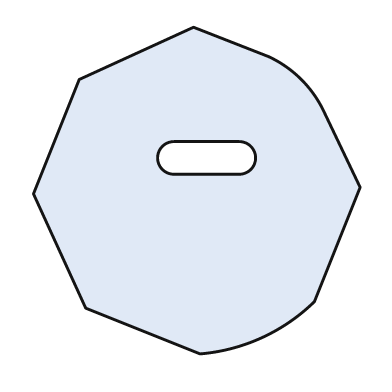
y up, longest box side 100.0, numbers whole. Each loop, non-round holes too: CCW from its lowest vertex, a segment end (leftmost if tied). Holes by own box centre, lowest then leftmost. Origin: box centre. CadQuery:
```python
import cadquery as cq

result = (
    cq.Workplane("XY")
    .moveTo(1.0, -50.0)
    .threePointArc((20.0, -45.0), (36.0, -34.0))
    .lineTo(50.0, 1.0)
    .lineTo(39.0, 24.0)
    .threePointArc((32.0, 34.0), (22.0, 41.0))
    .lineTo(-1.0, 50.0)
    .lineTo(-36.0, 34.0)
    .lineTo(-50.0, -1.0)
    .lineTo(-34.0, -36.0)
    .close()
    .moveTo(-7.0, 5.0)
    .lineTo(13.0, 5.0)
    .threePointArc((18.0, 10.0), (13.0, 15.0))
    .lineTo(-7.0, 15.0)
    .threePointArc((-12.0, 10.0), (-7.0, 5.0))
    .close()
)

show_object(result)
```